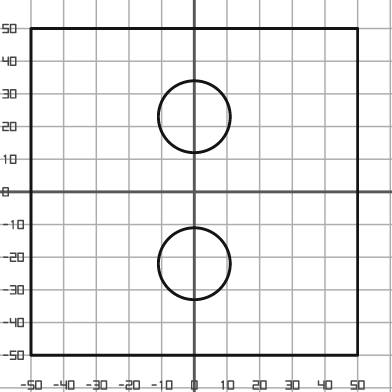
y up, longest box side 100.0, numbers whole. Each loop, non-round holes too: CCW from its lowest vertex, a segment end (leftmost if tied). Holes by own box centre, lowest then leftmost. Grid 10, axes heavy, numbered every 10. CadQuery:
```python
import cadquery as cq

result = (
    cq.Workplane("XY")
    .moveTo(-50.0, -50.0)
    .lineTo(50.0, -50.0)
    .lineTo(50.0, 50.0)
    .lineTo(-50.0, 50.0)
    .close()
    .moveTo(0.0, -22.0)
    .circle(11.0)
    .moveTo(0.0, 23.0)
    .circle(11.0)
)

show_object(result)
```